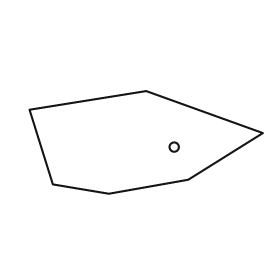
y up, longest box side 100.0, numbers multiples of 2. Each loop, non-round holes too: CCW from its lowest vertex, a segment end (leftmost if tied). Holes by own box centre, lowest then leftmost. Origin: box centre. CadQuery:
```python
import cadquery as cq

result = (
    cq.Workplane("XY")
    .moveTo(-16.0, -22.0)
    .lineTo(18.0, -16.0)
    .lineTo(50.0, 4.0)
    .lineTo(0.0, 22.0)
    .lineTo(-50.0, 14.0)
    .lineTo(-40.0, -18.0)
    .close()
    .moveTo(12.0, -2.0)
    .circle(2.0)
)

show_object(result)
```